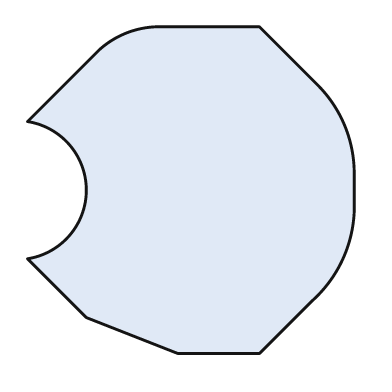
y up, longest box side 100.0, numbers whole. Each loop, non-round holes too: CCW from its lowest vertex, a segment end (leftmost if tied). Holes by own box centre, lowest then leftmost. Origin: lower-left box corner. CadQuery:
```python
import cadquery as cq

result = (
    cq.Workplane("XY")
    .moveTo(46.0, 0.0)
    .lineTo(71.0, 0.0)
    .lineTo(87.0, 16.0)
    .threePointArc((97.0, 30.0), (100.0, 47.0))
    .lineTo(100.0, 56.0)
    .threePointArc((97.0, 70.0), (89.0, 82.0))
    .lineTo(71.0, 100.0)
    .lineTo(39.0, 100.0)
    .threePointArc((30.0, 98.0), (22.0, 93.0))
    .lineTo(0.0, 71.0)
    .threePointArc((18.0, 50.0), (0.0, 29.0))
    .lineTo(18.0, 11.0)
    .close()
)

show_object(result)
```